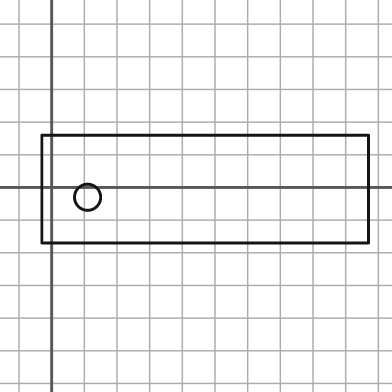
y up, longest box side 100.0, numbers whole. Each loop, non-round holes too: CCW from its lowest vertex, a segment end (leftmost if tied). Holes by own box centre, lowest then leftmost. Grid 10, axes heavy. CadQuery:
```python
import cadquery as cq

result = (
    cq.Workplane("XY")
    .moveTo(-3.0, -17.0)
    .lineTo(97.0, -17.0)
    .lineTo(97.0, 16.0)
    .lineTo(-3.0, 16.0)
    .close()
    .moveTo(11.0, -3.0)
    .circle(4.0)
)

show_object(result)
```